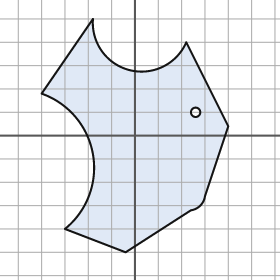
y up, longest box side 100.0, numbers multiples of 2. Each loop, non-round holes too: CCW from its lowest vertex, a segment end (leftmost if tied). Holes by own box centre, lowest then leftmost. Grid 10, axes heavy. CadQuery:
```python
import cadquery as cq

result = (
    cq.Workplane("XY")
    .moveTo(-4.0, -50.0)
    .lineTo(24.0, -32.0)
    .threePointArc((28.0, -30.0), (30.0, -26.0))
    .lineTo(40.0, 4.0)
    .lineTo(22.0, 40.0)
    .threePointArc((-2.0, 28.0), (-18.0, 50.0))
    .lineTo(-40.0, 18.0)
    .threePointArc((-18.0, -8.0), (-30.0, -40.0))
    .close()
    .moveTo(26.0, 10.0)
    .circle(2.0)
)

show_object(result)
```